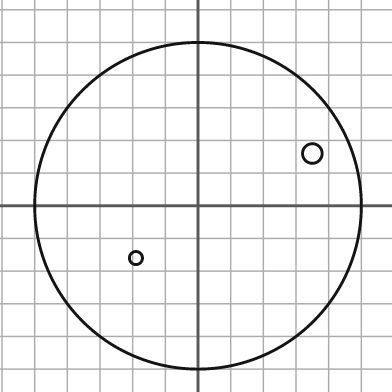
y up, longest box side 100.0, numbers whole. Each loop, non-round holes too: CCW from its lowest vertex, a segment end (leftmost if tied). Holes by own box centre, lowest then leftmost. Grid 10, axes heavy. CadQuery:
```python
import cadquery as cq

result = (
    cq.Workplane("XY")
    .moveTo(0.0, 0.0)
    .circle(50.0)
    .moveTo(-19.0, -16.0)
    .circle(2.0)
    .moveTo(35.0, 16.0)
    .circle(3.0)
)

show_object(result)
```